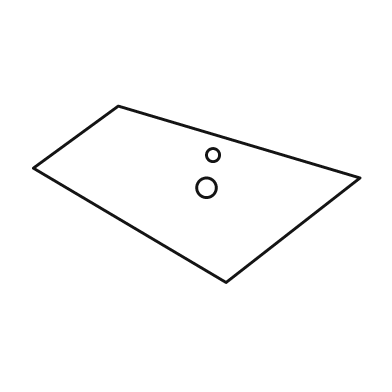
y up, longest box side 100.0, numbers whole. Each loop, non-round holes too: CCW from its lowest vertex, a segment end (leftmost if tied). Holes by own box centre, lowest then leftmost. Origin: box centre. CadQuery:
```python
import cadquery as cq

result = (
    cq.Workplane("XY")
    .moveTo(9.0, -27.0)
    .lineTo(50.0, 5.0)
    .lineTo(-24.0, 27.0)
    .lineTo(-50.0, 8.0)
    .close()
    .moveTo(3.0, 2.0)
    .circle(3.0)
    .moveTo(5.0, 12.0)
    .circle(2.0)
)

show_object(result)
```